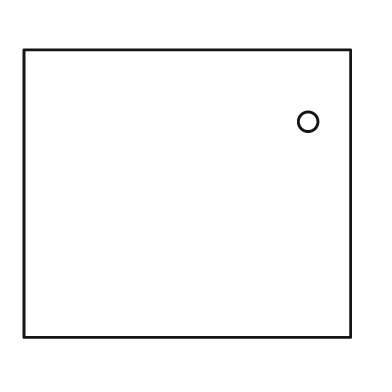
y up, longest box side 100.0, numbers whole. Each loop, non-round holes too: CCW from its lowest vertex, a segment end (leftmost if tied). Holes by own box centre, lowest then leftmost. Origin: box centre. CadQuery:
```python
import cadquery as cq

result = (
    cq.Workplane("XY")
    .moveTo(-50.0, -44.0)
    .lineTo(50.0, -44.0)
    .lineTo(50.0, 44.0)
    .lineTo(-50.0, 44.0)
    .close()
    .moveTo(37.0, 22.0)
    .circle(3.0)
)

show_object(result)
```